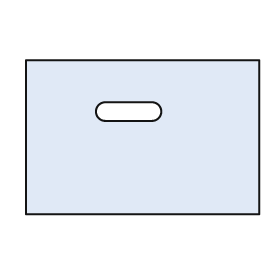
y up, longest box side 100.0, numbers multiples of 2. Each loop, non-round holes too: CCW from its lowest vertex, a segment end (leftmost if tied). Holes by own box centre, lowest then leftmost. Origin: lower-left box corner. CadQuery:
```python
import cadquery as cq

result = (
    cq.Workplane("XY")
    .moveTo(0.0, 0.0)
    .lineTo(100.0, 0.0)
    .lineTo(100.0, 66.0)
    .lineTo(0.0, 66.0)
    .close()
    .moveTo(34.0, 40.0)
    .lineTo(54.0, 40.0)
    .threePointArc((58.0, 44.0), (54.0, 48.0))
    .lineTo(34.0, 48.0)
    .threePointArc((30.0, 44.0), (34.0, 40.0))
    .close()
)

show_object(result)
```